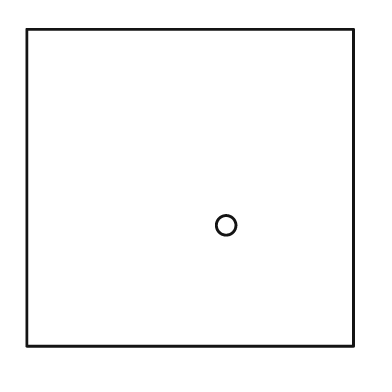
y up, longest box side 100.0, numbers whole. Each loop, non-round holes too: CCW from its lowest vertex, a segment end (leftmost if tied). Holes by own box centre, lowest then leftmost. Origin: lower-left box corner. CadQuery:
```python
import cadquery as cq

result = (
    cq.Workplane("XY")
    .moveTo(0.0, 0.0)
    .lineTo(100.0, 0.0)
    .lineTo(100.0, 97.0)
    .lineTo(0.0, 97.0)
    .close()
    .moveTo(61.0, 37.0)
    .circle(3.0)
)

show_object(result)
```